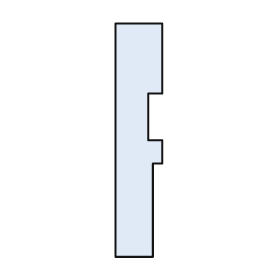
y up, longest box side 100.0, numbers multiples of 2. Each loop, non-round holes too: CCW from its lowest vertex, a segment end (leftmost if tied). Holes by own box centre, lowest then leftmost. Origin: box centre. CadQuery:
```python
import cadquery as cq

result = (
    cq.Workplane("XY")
    .moveTo(-10.0, -50.0)
    .lineTo(6.0, -50.0)
    .lineTo(6.0, -10.0)
    .lineTo(10.0, -10.0)
    .lineTo(10.0, 0.0)
    .lineTo(4.0, 0.0)
    .lineTo(4.0, 20.0)
    .lineTo(10.0, 20.0)
    .lineTo(10.0, 50.0)
    .lineTo(-10.0, 50.0)
    .close()
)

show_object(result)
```